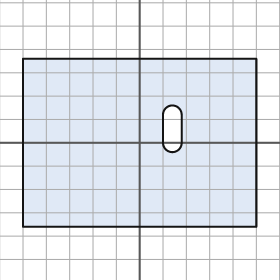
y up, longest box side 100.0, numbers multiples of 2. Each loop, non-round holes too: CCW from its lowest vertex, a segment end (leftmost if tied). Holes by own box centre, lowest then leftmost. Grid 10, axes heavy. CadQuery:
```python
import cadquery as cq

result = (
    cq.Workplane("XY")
    .moveTo(-50.0, -36.0)
    .lineTo(50.0, -36.0)
    .lineTo(50.0, 36.0)
    .lineTo(-50.0, 36.0)
    .close()
    .moveTo(10.0, 0.0)
    .threePointArc((14.0, -4.0), (18.0, 0.0))
    .lineTo(18.0, 12.0)
    .threePointArc((14.0, 16.0), (10.0, 12.0))
    .close()
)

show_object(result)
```